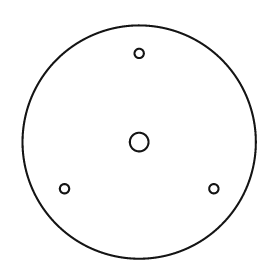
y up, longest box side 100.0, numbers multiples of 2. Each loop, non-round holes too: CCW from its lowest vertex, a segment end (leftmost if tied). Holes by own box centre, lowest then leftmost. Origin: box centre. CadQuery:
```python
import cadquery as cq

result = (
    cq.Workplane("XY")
    .moveTo(0.0, 0.0)
    .circle(50.0)
    .moveTo(-32.0, -20.0)
    .circle(2.0)
    .moveTo(32.0, -20.0)
    .circle(2.0)
    .moveTo(0.0, 0.0)
    .circle(4.0)
    .moveTo(0.0, 38.0)
    .circle(2.0)
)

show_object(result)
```